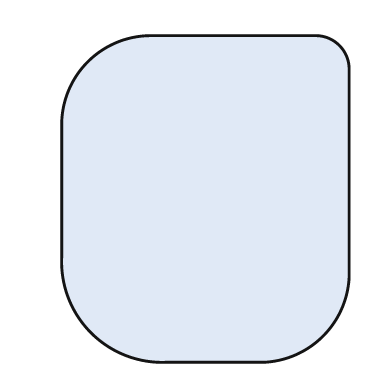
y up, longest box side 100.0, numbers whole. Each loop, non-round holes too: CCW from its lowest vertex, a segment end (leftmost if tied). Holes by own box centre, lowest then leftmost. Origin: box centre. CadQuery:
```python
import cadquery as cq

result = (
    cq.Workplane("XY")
    .moveTo(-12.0, -50.0)
    .lineTo(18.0, -50.0)
    .threePointArc((36.0, -42.0), (44.0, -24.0))
    .lineTo(44.0, 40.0)
    .threePointArc((41.0, 47.0), (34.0, 50.0))
    .lineTo(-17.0, 50.0)
    .threePointArc((-36.0, 42.0), (-44.0, 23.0))
    .lineTo(-44.0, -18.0)
    .threePointArc((-35.0, -41.0), (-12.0, -50.0))
    .close()
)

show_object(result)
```